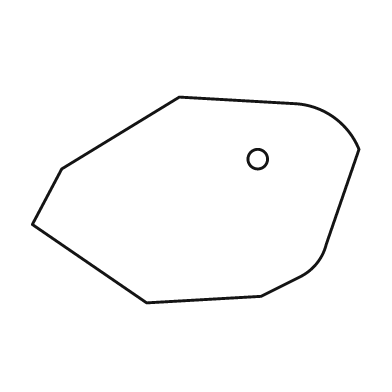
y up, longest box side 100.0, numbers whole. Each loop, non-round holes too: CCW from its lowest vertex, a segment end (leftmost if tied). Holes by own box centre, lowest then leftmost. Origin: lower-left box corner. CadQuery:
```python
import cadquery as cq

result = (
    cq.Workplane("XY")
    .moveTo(35.0, 0.0)
    .lineTo(70.0, 2.0)
    .lineTo(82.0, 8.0)
    .threePointArc((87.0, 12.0), (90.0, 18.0))
    .lineTo(100.0, 47.0)
    .threePointArc((92.0, 57.0), (80.0, 61.0))
    .lineTo(45.0, 63.0)
    .lineTo(9.0, 41.0)
    .lineTo(0.0, 24.0)
    .close()
    .moveTo(69.0, 44.0)
    .circle(3.0)
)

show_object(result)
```